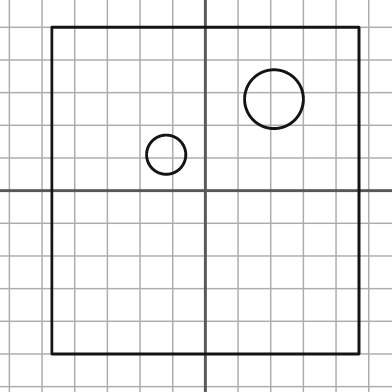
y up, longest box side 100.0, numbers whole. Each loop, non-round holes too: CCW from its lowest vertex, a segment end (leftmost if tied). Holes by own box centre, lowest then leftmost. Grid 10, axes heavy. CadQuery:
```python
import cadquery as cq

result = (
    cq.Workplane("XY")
    .moveTo(-47.0, -50.0)
    .lineTo(47.0, -50.0)
    .lineTo(47.0, 50.0)
    .lineTo(-47.0, 50.0)
    .close()
    .moveTo(-12.0, 11.0)
    .circle(6.0)
    .moveTo(21.0, 28.0)
    .circle(9.0)
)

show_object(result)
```